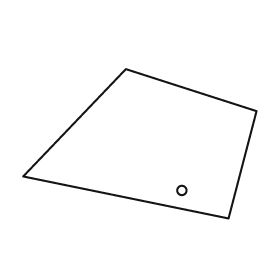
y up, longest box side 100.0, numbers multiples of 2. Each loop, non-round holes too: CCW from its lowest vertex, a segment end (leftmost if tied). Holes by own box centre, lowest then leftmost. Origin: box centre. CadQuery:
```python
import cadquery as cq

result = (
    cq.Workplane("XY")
    .moveTo(38.0, -32.0)
    .lineTo(50.0, 14.0)
    .lineTo(-6.0, 32.0)
    .lineTo(-50.0, -14.0)
    .close()
    .moveTo(18.0, -20.0)
    .circle(2.0)
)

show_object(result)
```